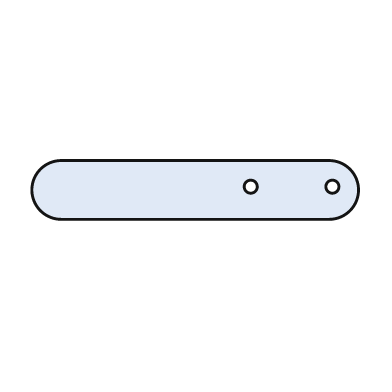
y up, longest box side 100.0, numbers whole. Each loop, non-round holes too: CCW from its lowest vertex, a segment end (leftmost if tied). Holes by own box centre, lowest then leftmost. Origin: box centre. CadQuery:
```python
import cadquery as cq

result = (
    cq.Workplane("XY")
    .moveTo(-41.0, -9.0)
    .lineTo(41.0, -9.0)
    .threePointArc((50.0, 0.0), (41.0, 9.0))
    .lineTo(-41.0, 9.0)
    .threePointArc((-50.0, 0.0), (-41.0, -9.0))
    .close()
    .moveTo(17.0, 1.0)
    .circle(2.0)
    .moveTo(42.0, 1.0)
    .circle(2.0)
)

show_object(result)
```